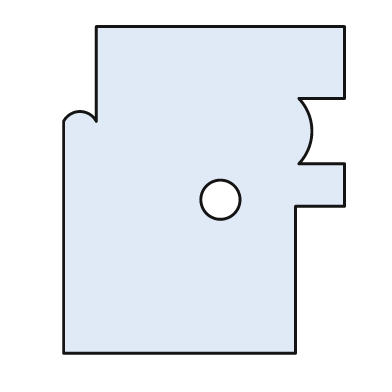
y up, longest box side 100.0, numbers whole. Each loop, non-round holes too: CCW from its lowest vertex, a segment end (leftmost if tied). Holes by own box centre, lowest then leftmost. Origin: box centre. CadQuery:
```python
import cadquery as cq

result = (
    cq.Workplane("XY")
    .moveTo(-43.0, -50.0)
    .lineTo(28.0, -50.0)
    .lineTo(28.0, -5.0)
    .lineTo(43.0, -5.0)
    .lineTo(43.0, 8.0)
    .lineTo(29.0, 8.0)
    .threePointArc((33.0, 18.0), (29.0, 28.0))
    .lineTo(43.0, 28.0)
    .lineTo(43.0, 50.0)
    .lineTo(-33.0, 50.0)
    .lineTo(-33.0, 21.0)
    .threePointArc((-38.0, 24.0), (-43.0, 21.0))
    .close()
    .moveTo(5.0, -3.0)
    .circle(6.0)
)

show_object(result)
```